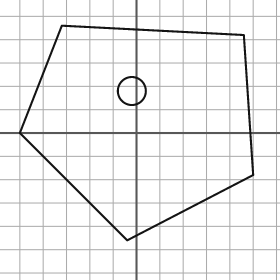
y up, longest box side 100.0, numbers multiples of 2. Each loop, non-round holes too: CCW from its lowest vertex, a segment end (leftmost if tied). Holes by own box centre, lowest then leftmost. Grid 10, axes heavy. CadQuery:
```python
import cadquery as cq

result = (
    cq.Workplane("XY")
    .moveTo(-4.0, -46.0)
    .lineTo(50.0, -18.0)
    .lineTo(46.0, 42.0)
    .lineTo(-32.0, 46.0)
    .lineTo(-50.0, 0.0)
    .close()
    .moveTo(-2.0, 18.0)
    .circle(6.0)
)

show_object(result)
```